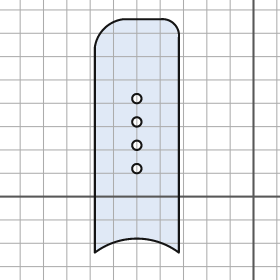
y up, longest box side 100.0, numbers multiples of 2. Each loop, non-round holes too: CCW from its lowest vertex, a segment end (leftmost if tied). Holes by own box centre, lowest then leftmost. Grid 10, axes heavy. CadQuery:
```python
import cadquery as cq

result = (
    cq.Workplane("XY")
    .moveTo(-68.0, -24.0)
    .threePointArc((-50.0, -18.0), (-32.0, -24.0))
    .lineTo(-32.0, 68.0)
    .threePointArc((-34.0, 74.0), (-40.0, 76.0))
    .lineTo(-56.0, 76.0)
    .threePointArc((-64.0, 72.0), (-68.0, 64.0))
    .close()
    .moveTo(-50.0, 12.0)
    .circle(2.0)
    .moveTo(-50.0, 22.0)
    .circle(2.0)
    .moveTo(-50.0, 32.0)
    .circle(2.0)
    .moveTo(-50.0, 42.0)
    .circle(2.0)
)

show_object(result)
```